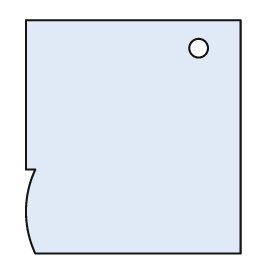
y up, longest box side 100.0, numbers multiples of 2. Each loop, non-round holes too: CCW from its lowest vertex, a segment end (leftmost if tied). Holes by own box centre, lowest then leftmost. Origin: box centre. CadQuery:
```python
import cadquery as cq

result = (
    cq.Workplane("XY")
    .moveTo(-42.0, -50.0)
    .lineTo(46.0, -50.0)
    .lineTo(46.0, 50.0)
    .lineTo(-46.0, 50.0)
    .lineTo(-46.0, -14.0)
    .lineTo(-42.0, -14.0)
    .threePointArc((-46.0, -32.0), (-42.0, -50.0))
    .close()
    .moveTo(28.0, 38.0)
    .circle(4.0)
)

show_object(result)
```